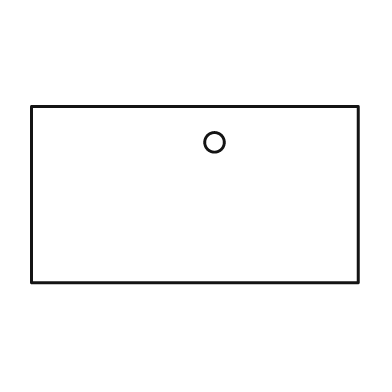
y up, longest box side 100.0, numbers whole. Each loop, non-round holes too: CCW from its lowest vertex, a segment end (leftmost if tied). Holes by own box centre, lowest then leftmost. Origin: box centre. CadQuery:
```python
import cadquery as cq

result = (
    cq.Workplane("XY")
    .moveTo(-50.0, -27.0)
    .lineTo(50.0, -27.0)
    .lineTo(50.0, 27.0)
    .lineTo(-50.0, 27.0)
    .close()
    .moveTo(6.0, 16.0)
    .circle(3.0)
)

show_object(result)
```